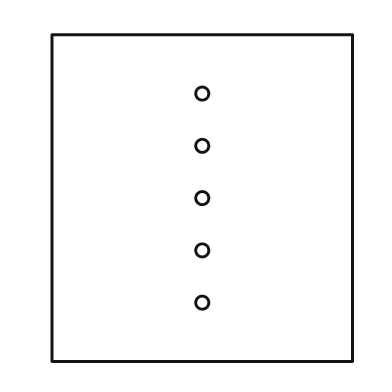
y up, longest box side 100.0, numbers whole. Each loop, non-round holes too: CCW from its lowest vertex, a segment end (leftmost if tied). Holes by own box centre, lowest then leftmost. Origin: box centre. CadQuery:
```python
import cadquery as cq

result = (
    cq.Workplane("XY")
    .moveTo(-46.0, -50.0)
    .lineTo(46.0, -50.0)
    .lineTo(46.0, 50.0)
    .lineTo(-46.0, 50.0)
    .close()
    .moveTo(0.0, -32.0)
    .circle(2.0)
    .moveTo(0.0, -16.0)
    .circle(2.0)
    .moveTo(0.0, 0.0)
    .circle(2.0)
    .moveTo(0.0, 16.0)
    .circle(2.0)
    .moveTo(0.0, 32.0)
    .circle(2.0)
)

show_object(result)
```